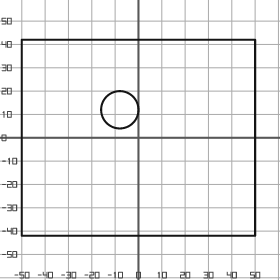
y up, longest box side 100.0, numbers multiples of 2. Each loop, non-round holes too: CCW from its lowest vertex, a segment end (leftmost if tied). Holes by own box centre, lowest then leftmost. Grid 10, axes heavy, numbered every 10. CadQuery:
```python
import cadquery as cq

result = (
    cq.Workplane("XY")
    .moveTo(-50.0, -42.0)
    .lineTo(50.0, -42.0)
    .lineTo(50.0, 42.0)
    .lineTo(-50.0, 42.0)
    .close()
    .moveTo(-8.0, 12.0)
    .circle(8.0)
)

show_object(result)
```